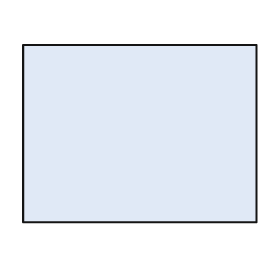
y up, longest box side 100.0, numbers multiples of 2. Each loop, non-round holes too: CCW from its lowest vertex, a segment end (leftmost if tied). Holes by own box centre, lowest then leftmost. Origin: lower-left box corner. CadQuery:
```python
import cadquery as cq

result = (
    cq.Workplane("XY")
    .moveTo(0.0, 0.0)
    .lineTo(100.0, 0.0)
    .lineTo(100.0, 76.0)
    .lineTo(0.0, 76.0)
    .close()
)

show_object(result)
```